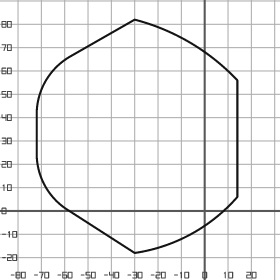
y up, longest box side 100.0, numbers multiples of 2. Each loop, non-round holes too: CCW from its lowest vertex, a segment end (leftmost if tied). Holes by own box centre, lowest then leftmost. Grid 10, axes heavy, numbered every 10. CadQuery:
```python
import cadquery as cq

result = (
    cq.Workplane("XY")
    .moveTo(-30.0, -18.0)
    .threePointArc((-6.0, -10.0), (14.0, 6.0))
    .lineTo(14.0, 56.0)
    .threePointArc((-6.0, 72.0), (-30.0, 82.0))
    .lineTo(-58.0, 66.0)
    .threePointArc((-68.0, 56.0), (-72.0, 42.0))
    .lineTo(-72.0, 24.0)
    .threePointArc((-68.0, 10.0), (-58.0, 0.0))
    .close()
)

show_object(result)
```